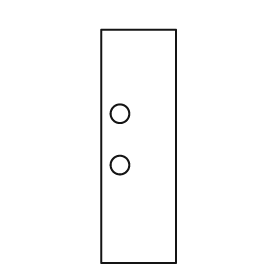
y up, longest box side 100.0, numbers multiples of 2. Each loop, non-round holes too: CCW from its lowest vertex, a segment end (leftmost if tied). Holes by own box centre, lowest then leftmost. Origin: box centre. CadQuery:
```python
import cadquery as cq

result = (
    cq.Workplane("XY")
    .moveTo(-16.0, -50.0)
    .lineTo(16.0, -50.0)
    .lineTo(16.0, 50.0)
    .lineTo(-16.0, 50.0)
    .close()
    .moveTo(-8.0, -8.0)
    .circle(4.0)
    .moveTo(-8.0, 14.0)
    .circle(4.0)
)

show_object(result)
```